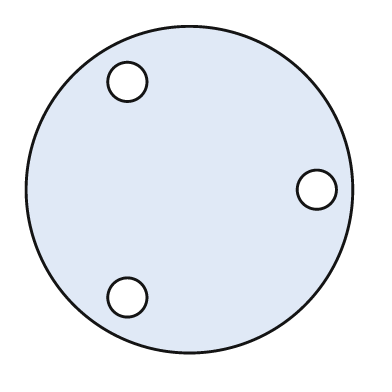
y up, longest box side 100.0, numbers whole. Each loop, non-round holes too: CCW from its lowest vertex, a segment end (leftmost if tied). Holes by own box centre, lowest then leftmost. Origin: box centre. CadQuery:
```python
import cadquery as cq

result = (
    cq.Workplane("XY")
    .moveTo(0.0, 0.0)
    .circle(50.0)
    .moveTo(-19.0, -33.0)
    .circle(6.0)
    .moveTo(39.0, 0.0)
    .circle(6.0)
    .moveTo(-19.0, 33.0)
    .circle(6.0)
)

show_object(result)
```